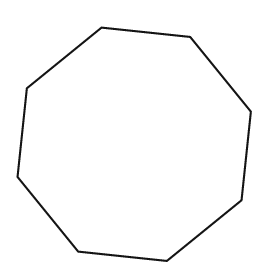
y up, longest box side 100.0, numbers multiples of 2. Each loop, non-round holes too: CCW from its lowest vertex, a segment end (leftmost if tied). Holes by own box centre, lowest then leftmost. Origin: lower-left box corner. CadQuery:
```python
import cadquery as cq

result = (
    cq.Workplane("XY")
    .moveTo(64.0, 0.0)
    .lineTo(96.0, 26.0)
    .lineTo(100.0, 64.0)
    .lineTo(74.0, 96.0)
    .lineTo(36.0, 100.0)
    .lineTo(4.0, 74.0)
    .lineTo(0.0, 36.0)
    .lineTo(26.0, 4.0)
    .close()
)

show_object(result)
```